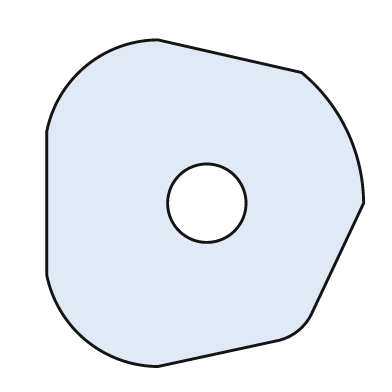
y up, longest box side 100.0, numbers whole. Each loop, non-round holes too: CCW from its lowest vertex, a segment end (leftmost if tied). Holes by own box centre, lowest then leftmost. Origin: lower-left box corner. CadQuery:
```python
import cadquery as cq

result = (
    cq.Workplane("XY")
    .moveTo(34.0, 0.0)
    .lineTo(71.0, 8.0)
    .threePointArc((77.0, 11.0), (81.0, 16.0))
    .lineTo(97.0, 50.0)
    .threePointArc((92.0, 72.0), (78.0, 90.0))
    .lineTo(34.0, 100.0)
    .threePointArc((12.0, 92.0), (0.0, 72.0))
    .lineTo(0.0, 28.0)
    .threePointArc((12.0, 8.0), (34.0, 0.0))
    .close()
    .moveTo(49.0, 50.0)
    .circle(12.0)
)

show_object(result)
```